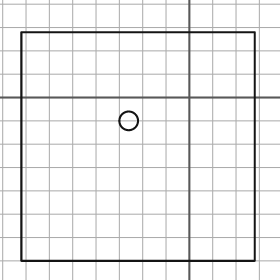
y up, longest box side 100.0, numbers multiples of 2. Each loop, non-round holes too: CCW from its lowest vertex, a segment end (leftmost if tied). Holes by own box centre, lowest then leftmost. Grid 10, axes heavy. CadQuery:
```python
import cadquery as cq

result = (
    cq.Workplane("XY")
    .moveTo(-72.0, -70.0)
    .lineTo(28.0, -70.0)
    .lineTo(28.0, 28.0)
    .lineTo(-72.0, 28.0)
    .close()
    .moveTo(-26.0, -10.0)
    .circle(4.0)
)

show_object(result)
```